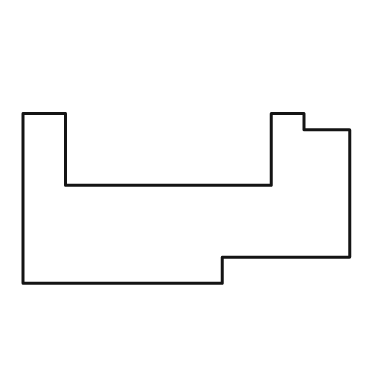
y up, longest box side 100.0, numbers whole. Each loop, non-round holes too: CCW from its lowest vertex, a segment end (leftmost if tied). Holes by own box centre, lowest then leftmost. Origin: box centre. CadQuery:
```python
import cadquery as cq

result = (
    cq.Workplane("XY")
    .moveTo(-50.0, -26.0)
    .lineTo(11.0, -26.0)
    .lineTo(11.0, -18.0)
    .lineTo(50.0, -18.0)
    .lineTo(50.0, 21.0)
    .lineTo(36.0, 21.0)
    .lineTo(36.0, 26.0)
    .lineTo(26.0, 26.0)
    .lineTo(26.0, 4.0)
    .lineTo(-37.0, 4.0)
    .lineTo(-37.0, 26.0)
    .lineTo(-50.0, 26.0)
    .close()
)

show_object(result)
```